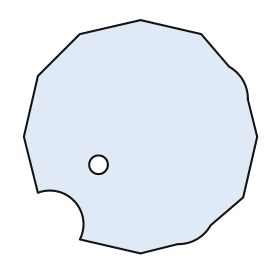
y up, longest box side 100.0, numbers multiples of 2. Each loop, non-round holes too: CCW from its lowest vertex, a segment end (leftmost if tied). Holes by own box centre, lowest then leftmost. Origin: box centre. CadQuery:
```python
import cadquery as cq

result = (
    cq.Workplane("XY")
    .moveTo(0.0, -50.0)
    .lineTo(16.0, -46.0)
    .threePointArc((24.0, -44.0), (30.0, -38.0))
    .lineTo(44.0, -26.0)
    .lineTo(50.0, 0.0)
    .lineTo(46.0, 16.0)
    .threePointArc((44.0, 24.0), (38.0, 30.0))
    .lineTo(26.0, 44.0)
    .lineTo(0.0, 50.0)
    .lineTo(-26.0, 44.0)
    .lineTo(-44.0, 26.0)
    .lineTo(-50.0, 0.0)
    .lineTo(-44.0, -24.0)
    .threePointArc((-28.0, -28.0), (-26.0, -44.0))
    .close()
    .moveTo(-18.0, -12.0)
    .circle(4.0)
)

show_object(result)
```